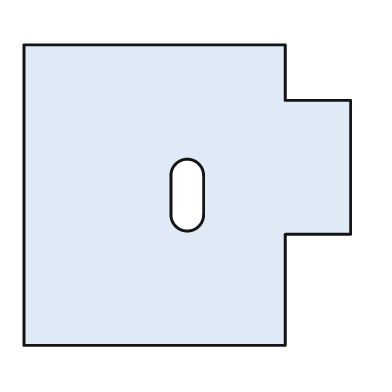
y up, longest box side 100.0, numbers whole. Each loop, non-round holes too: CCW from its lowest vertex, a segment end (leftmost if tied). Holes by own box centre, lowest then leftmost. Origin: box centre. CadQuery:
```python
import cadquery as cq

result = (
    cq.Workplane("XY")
    .moveTo(-50.0, -46.0)
    .lineTo(30.0, -46.0)
    .lineTo(30.0, -12.0)
    .lineTo(50.0, -12.0)
    .lineTo(50.0, 29.0)
    .lineTo(30.0, 29.0)
    .lineTo(30.0, 46.0)
    .lineTo(-50.0, 46.0)
    .close()
    .moveTo(-5.0, -6.0)
    .threePointArc((0.0, -11.0), (5.0, -6.0))
    .lineTo(5.0, 6.0)
    .threePointArc((0.0, 11.0), (-5.0, 6.0))
    .close()
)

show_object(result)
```